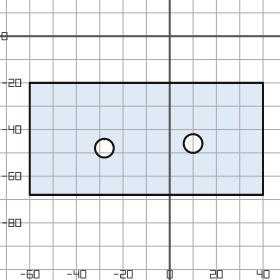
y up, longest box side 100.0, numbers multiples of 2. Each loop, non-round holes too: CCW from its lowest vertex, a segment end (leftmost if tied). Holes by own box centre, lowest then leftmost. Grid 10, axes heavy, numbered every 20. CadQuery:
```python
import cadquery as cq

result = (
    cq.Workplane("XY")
    .moveTo(-60.0, -68.0)
    .lineTo(40.0, -68.0)
    .lineTo(40.0, -20.0)
    .lineTo(-60.0, -20.0)
    .close()
    .moveTo(-28.0, -48.0)
    .circle(4.0)
    .moveTo(10.0, -46.0)
    .circle(4.0)
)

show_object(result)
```